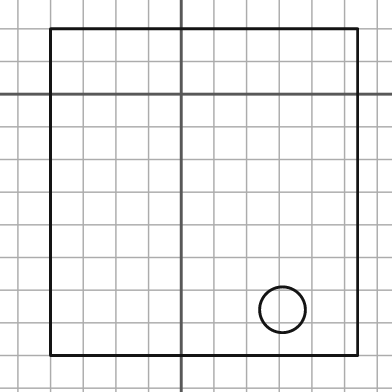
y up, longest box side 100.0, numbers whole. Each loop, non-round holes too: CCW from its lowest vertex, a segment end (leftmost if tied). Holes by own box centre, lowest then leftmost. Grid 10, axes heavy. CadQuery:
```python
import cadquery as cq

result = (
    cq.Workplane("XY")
    .moveTo(-40.0, -80.0)
    .lineTo(54.0, -80.0)
    .lineTo(54.0, 20.0)
    .lineTo(-40.0, 20.0)
    .close()
    .moveTo(31.0, -66.0)
    .circle(7.0)
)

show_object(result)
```